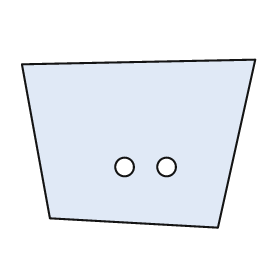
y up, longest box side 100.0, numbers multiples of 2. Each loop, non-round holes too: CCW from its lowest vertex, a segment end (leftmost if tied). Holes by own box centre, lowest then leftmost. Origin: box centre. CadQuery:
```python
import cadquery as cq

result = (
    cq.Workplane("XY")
    .moveTo(34.0, -36.0)
    .lineTo(50.0, 36.0)
    .lineTo(-50.0, 34.0)
    .lineTo(-38.0, -32.0)
    .close()
    .moveTo(-6.0, -10.0)
    .circle(4.0)
    .moveTo(12.0, -10.0)
    .circle(4.0)
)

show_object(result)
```